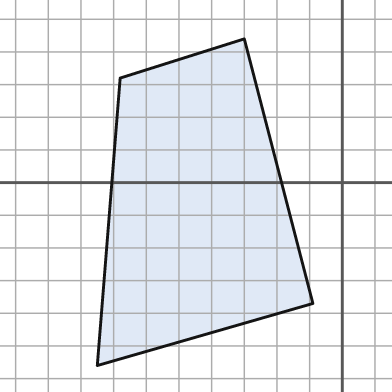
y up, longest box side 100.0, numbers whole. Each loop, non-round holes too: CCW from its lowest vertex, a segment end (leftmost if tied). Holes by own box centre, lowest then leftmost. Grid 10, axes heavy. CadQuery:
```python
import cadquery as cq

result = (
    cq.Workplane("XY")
    .moveTo(-75.0, -56.0)
    .lineTo(-9.0, -37.0)
    .lineTo(-30.0, 44.0)
    .lineTo(-68.0, 32.0)
    .close()
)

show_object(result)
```